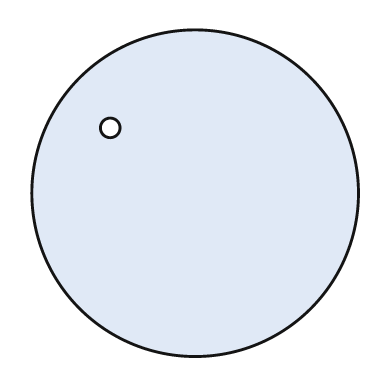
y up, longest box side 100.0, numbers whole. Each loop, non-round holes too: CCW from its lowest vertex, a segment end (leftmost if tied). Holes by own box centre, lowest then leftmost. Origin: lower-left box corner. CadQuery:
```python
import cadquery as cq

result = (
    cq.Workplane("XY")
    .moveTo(50.0, 50.0)
    .circle(50.0)
    .moveTo(24.0, 70.0)
    .circle(3.0)
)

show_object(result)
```